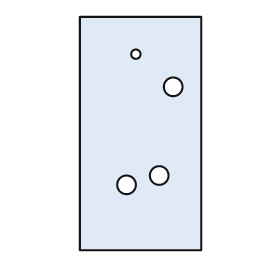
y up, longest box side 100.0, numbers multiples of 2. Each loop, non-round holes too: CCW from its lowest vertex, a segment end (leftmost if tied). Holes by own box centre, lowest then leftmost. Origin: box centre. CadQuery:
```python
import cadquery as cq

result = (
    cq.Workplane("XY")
    .moveTo(-26.0, -50.0)
    .lineTo(26.0, -50.0)
    .lineTo(26.0, 50.0)
    .lineTo(-26.0, 50.0)
    .close()
    .moveTo(-6.0, -22.0)
    .circle(4.0)
    .moveTo(8.0, -18.0)
    .circle(4.0)
    .moveTo(14.0, 20.0)
    .circle(4.0)
    .moveTo(-2.0, 34.0)
    .circle(2.0)
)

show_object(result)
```